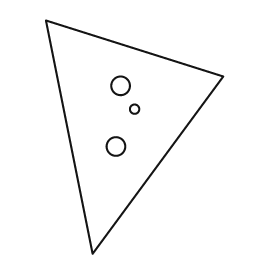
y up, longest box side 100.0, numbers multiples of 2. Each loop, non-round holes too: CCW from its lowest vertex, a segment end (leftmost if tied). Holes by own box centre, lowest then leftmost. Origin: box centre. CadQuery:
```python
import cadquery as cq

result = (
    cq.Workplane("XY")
    .moveTo(-18.0, -50.0)
    .lineTo(38.0, 26.0)
    .lineTo(-38.0, 50.0)
    .close()
    .moveTo(-8.0, -4.0)
    .circle(4.0)
    .moveTo(0.0, 12.0)
    .circle(2.0)
    .moveTo(-6.0, 22.0)
    .circle(4.0)
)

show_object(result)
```